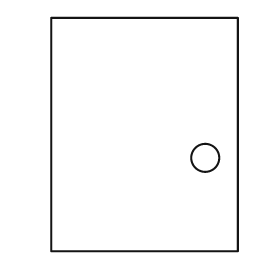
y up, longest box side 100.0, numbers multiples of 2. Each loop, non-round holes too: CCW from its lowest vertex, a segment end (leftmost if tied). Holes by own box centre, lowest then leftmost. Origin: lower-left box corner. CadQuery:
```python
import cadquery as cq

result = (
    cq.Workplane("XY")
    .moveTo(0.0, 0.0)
    .lineTo(80.0, 0.0)
    .lineTo(80.0, 100.0)
    .lineTo(0.0, 100.0)
    .close()
    .moveTo(66.0, 40.0)
    .circle(6.0)
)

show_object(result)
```